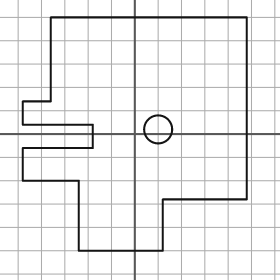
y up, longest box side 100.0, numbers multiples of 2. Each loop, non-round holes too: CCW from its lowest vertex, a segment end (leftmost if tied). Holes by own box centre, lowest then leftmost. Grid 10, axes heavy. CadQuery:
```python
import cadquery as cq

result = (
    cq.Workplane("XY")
    .moveTo(-24.0, -50.0)
    .lineTo(12.0, -50.0)
    .lineTo(12.0, -28.0)
    .lineTo(48.0, -28.0)
    .lineTo(48.0, 50.0)
    .lineTo(-36.0, 50.0)
    .lineTo(-36.0, 14.0)
    .lineTo(-48.0, 14.0)
    .lineTo(-48.0, 4.0)
    .lineTo(-18.0, 4.0)
    .lineTo(-18.0, -6.0)
    .lineTo(-48.0, -6.0)
    .lineTo(-48.0, -20.0)
    .lineTo(-24.0, -20.0)
    .close()
    .moveTo(10.0, 2.0)
    .circle(6.0)
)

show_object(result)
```